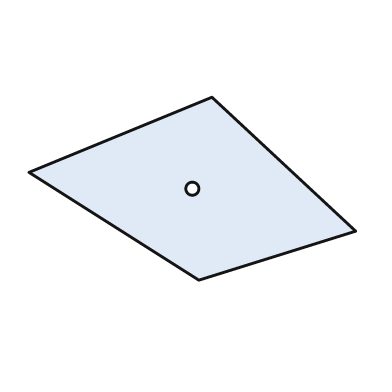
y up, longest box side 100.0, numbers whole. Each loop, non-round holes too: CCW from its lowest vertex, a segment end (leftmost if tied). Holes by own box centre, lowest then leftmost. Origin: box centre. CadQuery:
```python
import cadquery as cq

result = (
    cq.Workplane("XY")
    .moveTo(2.0, -28.0)
    .lineTo(50.0, -13.0)
    .lineTo(6.0, 28.0)
    .lineTo(-50.0, 5.0)
    .close()
    .moveTo(0.0, 0.0)
    .circle(2.0)
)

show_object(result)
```